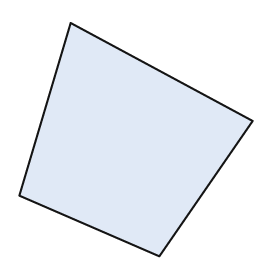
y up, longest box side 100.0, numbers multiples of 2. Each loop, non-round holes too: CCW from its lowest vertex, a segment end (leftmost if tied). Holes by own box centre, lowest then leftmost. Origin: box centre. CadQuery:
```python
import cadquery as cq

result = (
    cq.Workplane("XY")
    .moveTo(10.0, -50.0)
    .lineTo(50.0, 8.0)
    .lineTo(-28.0, 50.0)
    .lineTo(-50.0, -24.0)
    .close()
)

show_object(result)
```